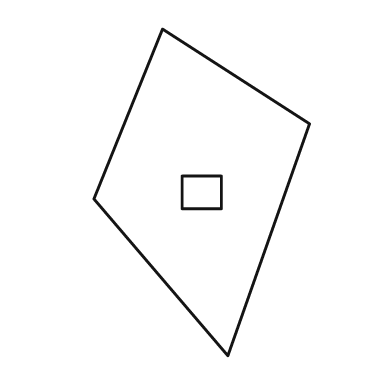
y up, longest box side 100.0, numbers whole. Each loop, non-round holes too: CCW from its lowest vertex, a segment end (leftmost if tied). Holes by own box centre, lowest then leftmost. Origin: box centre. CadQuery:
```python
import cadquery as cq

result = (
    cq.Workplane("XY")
    .moveTo(8.0, -50.0)
    .lineTo(33.0, 21.0)
    .lineTo(-12.0, 50.0)
    .lineTo(-33.0, -2.0)
    .close()
    .moveTo(-6.0, -5.0)
    .lineTo(6.0, -5.0)
    .lineTo(6.0, 5.0)
    .lineTo(-6.0, 5.0)
    .close()
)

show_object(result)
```